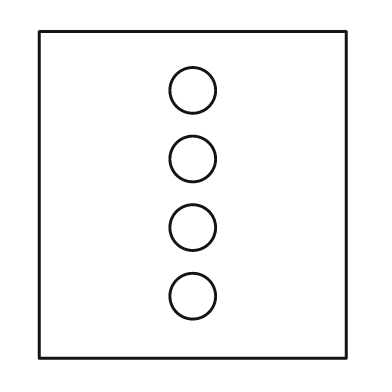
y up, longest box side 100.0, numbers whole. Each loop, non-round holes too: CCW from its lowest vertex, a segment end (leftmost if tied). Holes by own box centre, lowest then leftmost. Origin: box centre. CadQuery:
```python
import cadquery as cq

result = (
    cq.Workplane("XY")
    .moveTo(-47.0, -50.0)
    .lineTo(47.0, -50.0)
    .lineTo(47.0, 50.0)
    .lineTo(-47.0, 50.0)
    .close()
    .moveTo(0.0, -31.0)
    .circle(7.0)
    .moveTo(0.0, -10.0)
    .circle(7.0)
    .moveTo(0.0, 11.0)
    .circle(7.0)
    .moveTo(0.0, 32.0)
    .circle(7.0)
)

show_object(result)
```